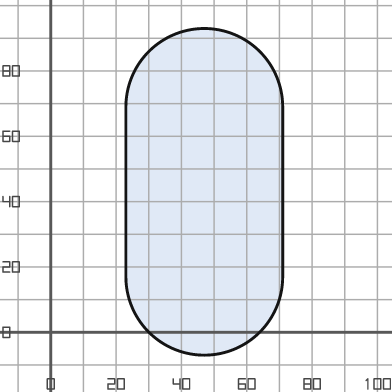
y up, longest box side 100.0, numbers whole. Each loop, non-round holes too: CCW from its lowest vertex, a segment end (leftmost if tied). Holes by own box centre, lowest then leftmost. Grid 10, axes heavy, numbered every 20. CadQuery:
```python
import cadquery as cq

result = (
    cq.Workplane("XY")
    .moveTo(23.0, 17.0)
    .threePointArc((47.0, -7.0), (71.0, 17.0))
    .lineTo(71.0, 69.0)
    .threePointArc((47.0, 93.0), (23.0, 69.0))
    .close()
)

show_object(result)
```